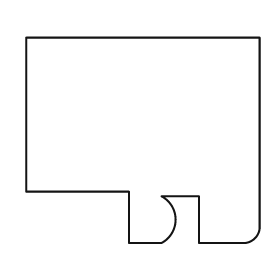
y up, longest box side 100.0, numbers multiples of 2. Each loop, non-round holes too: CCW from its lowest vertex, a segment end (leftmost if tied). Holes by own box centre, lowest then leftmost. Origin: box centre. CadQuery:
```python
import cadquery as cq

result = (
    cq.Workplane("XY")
    .moveTo(-6.0, -44.0)
    .lineTo(8.0, -44.0)
    .threePointArc((14.0, -34.0), (8.0, -24.0))
    .lineTo(24.0, -24.0)
    .lineTo(24.0, -44.0)
    .lineTo(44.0, -44.0)
    .threePointArc((48.0, -42.0), (50.0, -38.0))
    .lineTo(50.0, 44.0)
    .lineTo(-50.0, 44.0)
    .lineTo(-50.0, -22.0)
    .lineTo(-6.0, -22.0)
    .close()
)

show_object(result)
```